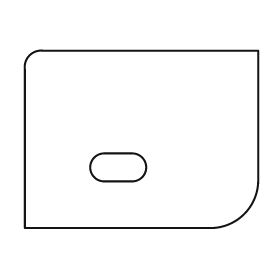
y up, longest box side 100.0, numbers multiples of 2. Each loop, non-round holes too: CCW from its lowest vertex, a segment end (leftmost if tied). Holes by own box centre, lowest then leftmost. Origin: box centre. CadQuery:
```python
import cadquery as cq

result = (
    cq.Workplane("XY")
    .moveTo(-50.0, -38.0)
    .lineTo(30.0, -38.0)
    .threePointArc((44.0, -32.0), (50.0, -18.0))
    .lineTo(50.0, 38.0)
    .lineTo(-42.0, 38.0)
    .threePointArc((-48.0, 36.0), (-50.0, 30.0))
    .close()
    .moveTo(-16.0, -18.0)
    .lineTo(-4.0, -18.0)
    .threePointArc((2.0, -12.0), (-4.0, -6.0))
    .lineTo(-16.0, -6.0)
    .threePointArc((-22.0, -12.0), (-16.0, -18.0))
    .close()
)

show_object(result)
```